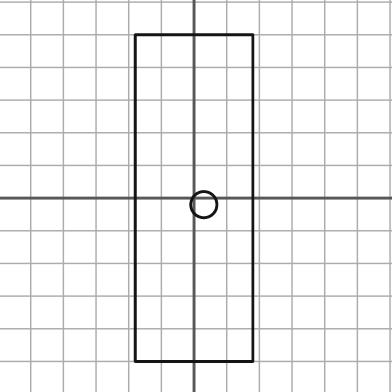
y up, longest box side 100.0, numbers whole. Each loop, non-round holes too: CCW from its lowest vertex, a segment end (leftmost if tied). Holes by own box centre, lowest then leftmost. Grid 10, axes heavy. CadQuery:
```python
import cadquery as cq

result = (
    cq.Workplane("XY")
    .moveTo(-18.0, -50.0)
    .lineTo(18.0, -50.0)
    .lineTo(18.0, 50.0)
    .lineTo(-18.0, 50.0)
    .close()
    .moveTo(3.0, -2.0)
    .circle(4.0)
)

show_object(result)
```